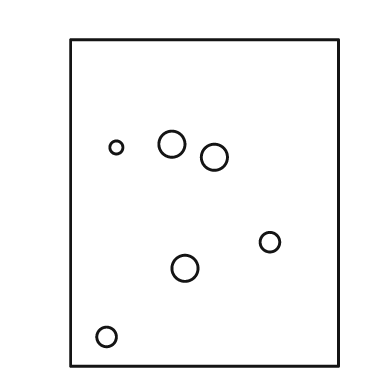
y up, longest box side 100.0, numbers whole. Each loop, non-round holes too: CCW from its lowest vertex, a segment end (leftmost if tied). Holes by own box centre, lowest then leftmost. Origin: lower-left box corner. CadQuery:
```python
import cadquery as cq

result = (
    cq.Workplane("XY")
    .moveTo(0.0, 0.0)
    .lineTo(82.0, 0.0)
    .lineTo(82.0, 100.0)
    .lineTo(0.0, 100.0)
    .close()
    .moveTo(11.0, 9.0)
    .circle(3.0)
    .moveTo(35.0, 30.0)
    .circle(4.0)
    .moveTo(61.0, 38.0)
    .circle(3.0)
    .moveTo(44.0, 64.0)
    .circle(4.0)
    .moveTo(14.0, 67.0)
    .circle(2.0)
    .moveTo(31.0, 68.0)
    .circle(4.0)
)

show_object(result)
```